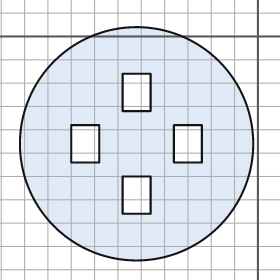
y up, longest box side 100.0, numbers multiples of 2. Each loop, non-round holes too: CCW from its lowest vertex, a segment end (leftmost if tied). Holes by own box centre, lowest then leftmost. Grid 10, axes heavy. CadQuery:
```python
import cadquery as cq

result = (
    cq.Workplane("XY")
    .moveTo(-52.0, -46.0)
    .circle(50.0)
    .moveTo(-58.0, -76.0)
    .lineTo(-46.0, -76.0)
    .lineTo(-46.0, -60.0)
    .lineTo(-58.0, -60.0)
    .close()
    .moveTo(-80.0, -54.0)
    .lineTo(-68.0, -54.0)
    .lineTo(-68.0, -38.0)
    .lineTo(-80.0, -38.0)
    .close()
    .moveTo(-36.0, -54.0)
    .lineTo(-24.0, -54.0)
    .lineTo(-24.0, -38.0)
    .lineTo(-36.0, -38.0)
    .close()
    .moveTo(-58.0, -32.0)
    .lineTo(-46.0, -32.0)
    .lineTo(-46.0, -16.0)
    .lineTo(-58.0, -16.0)
    .close()
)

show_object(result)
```